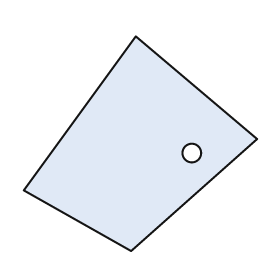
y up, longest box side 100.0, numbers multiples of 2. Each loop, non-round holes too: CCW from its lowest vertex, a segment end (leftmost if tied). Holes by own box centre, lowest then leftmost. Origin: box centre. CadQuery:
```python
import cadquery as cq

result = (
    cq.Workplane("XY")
    .moveTo(-4.0, -46.0)
    .lineTo(50.0, 2.0)
    .lineTo(-2.0, 46.0)
    .lineTo(-50.0, -20.0)
    .close()
    .moveTo(22.0, -4.0)
    .circle(4.0)
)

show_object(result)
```